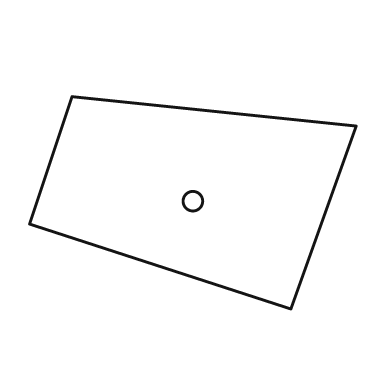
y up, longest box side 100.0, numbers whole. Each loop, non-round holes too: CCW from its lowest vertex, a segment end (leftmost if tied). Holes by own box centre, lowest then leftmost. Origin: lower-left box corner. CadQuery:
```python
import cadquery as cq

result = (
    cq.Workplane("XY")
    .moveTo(80.0, 0.0)
    .lineTo(100.0, 56.0)
    .lineTo(13.0, 65.0)
    .lineTo(0.0, 26.0)
    .close()
    .moveTo(50.0, 33.0)
    .circle(3.0)
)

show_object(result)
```